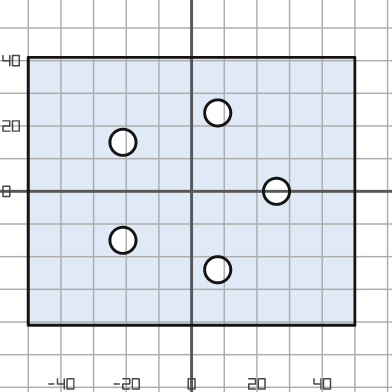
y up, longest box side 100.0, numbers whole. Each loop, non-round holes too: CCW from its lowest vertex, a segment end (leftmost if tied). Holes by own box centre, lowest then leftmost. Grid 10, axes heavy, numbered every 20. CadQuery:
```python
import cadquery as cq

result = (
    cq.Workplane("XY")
    .moveTo(-50.0, -41.0)
    .lineTo(50.0, -41.0)
    .lineTo(50.0, 41.0)
    .lineTo(-50.0, 41.0)
    .close()
    .moveTo(8.0, -24.0)
    .circle(4.0)
    .moveTo(-21.0, -15.0)
    .circle(4.0)
    .moveTo(26.0, 0.0)
    .circle(4.0)
    .moveTo(-21.0, 15.0)
    .circle(4.0)
    .moveTo(8.0, 24.0)
    .circle(4.0)
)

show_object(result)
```